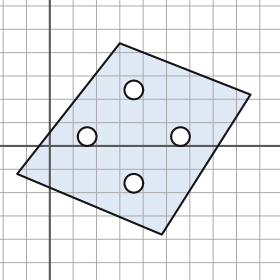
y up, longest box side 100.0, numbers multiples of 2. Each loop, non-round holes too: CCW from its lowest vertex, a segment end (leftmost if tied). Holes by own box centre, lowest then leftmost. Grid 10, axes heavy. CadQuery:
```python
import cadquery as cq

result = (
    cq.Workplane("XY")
    .moveTo(48.0, -38.0)
    .lineTo(86.0, 22.0)
    .lineTo(30.0, 44.0)
    .lineTo(-14.0, -12.0)
    .close()
    .moveTo(36.0, -16.0)
    .circle(4.0)
    .moveTo(16.0, 4.0)
    .circle(4.0)
    .moveTo(56.0, 4.0)
    .circle(4.0)
    .moveTo(36.0, 24.0)
    .circle(4.0)
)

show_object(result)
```